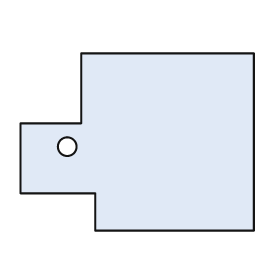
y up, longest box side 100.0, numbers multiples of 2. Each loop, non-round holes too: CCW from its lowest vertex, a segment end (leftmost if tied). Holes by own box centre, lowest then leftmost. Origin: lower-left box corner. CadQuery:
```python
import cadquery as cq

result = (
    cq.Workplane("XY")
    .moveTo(32.0, 0.0)
    .lineTo(100.0, 0.0)
    .lineTo(100.0, 76.0)
    .lineTo(26.0, 76.0)
    .lineTo(26.0, 46.0)
    .lineTo(0.0, 46.0)
    .lineTo(0.0, 16.0)
    .lineTo(32.0, 16.0)
    .close()
    .moveTo(20.0, 36.0)
    .circle(4.0)
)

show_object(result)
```